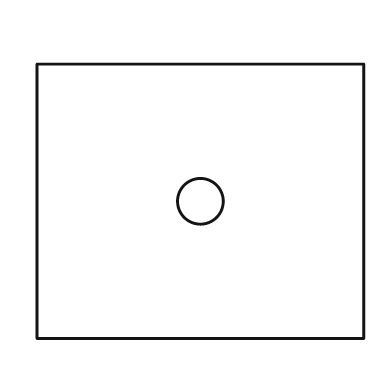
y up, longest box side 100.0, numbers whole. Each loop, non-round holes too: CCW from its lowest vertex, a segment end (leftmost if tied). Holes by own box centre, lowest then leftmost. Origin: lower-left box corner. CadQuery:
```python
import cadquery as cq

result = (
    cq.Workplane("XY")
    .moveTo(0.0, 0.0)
    .lineTo(100.0, 0.0)
    .lineTo(100.0, 84.0)
    .lineTo(0.0, 84.0)
    .close()
    .moveTo(50.0, 42.0)
    .circle(7.0)
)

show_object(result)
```